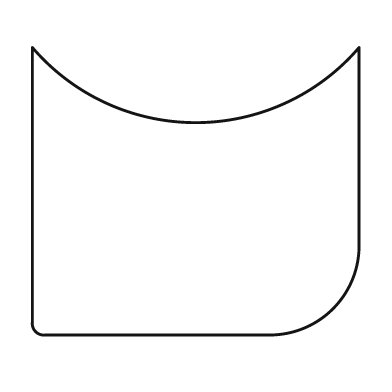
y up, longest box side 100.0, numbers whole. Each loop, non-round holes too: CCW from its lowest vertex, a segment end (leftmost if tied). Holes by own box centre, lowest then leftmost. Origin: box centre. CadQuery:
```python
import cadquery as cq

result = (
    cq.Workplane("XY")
    .moveTo(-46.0, -44.0)
    .lineTo(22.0, -44.0)
    .threePointArc((42.0, -36.0), (50.0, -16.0))
    .lineTo(50.0, 44.0)
    .threePointArc((0.0, 21.0), (-50.0, 44.0))
    .lineTo(-50.0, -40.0)
    .threePointArc((-49.0, -43.0), (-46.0, -44.0))
    .close()
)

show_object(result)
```